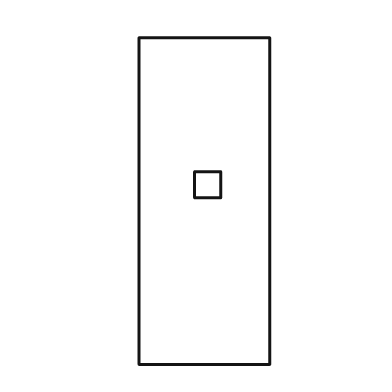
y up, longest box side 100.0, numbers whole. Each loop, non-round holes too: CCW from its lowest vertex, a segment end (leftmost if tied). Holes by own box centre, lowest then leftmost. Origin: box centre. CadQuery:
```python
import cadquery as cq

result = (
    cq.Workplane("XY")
    .moveTo(-20.0, -50.0)
    .lineTo(20.0, -50.0)
    .lineTo(20.0, 50.0)
    .lineTo(-20.0, 50.0)
    .close()
    .moveTo(-3.0, 1.0)
    .lineTo(5.0, 1.0)
    .lineTo(5.0, 9.0)
    .lineTo(-3.0, 9.0)
    .close()
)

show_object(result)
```